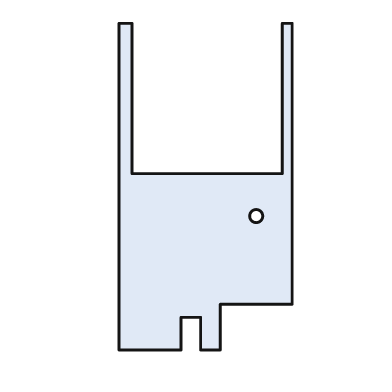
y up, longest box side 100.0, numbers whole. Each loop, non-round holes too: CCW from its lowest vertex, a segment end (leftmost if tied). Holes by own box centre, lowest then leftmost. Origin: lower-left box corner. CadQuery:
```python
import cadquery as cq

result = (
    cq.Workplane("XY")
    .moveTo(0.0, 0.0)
    .lineTo(19.0, 0.0)
    .lineTo(19.0, 10.0)
    .lineTo(25.0, 10.0)
    .lineTo(25.0, 0.0)
    .lineTo(31.0, 0.0)
    .lineTo(31.0, 14.0)
    .lineTo(53.0, 14.0)
    .lineTo(53.0, 100.0)
    .lineTo(50.0, 100.0)
    .lineTo(50.0, 54.0)
    .lineTo(4.0, 54.0)
    .lineTo(4.0, 100.0)
    .lineTo(0.0, 100.0)
    .close()
    .moveTo(42.0, 41.0)
    .circle(2.0)
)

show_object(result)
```